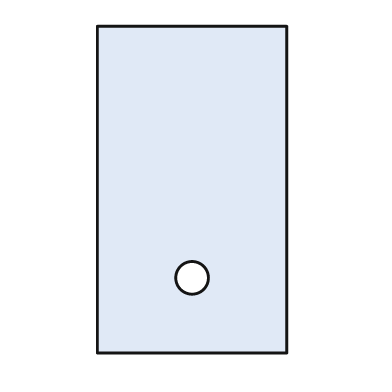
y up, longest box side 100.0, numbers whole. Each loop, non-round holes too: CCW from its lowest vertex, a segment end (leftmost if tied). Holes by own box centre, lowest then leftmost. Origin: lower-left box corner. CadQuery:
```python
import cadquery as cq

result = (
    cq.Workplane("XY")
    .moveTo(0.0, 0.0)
    .lineTo(58.0, 0.0)
    .lineTo(58.0, 100.0)
    .lineTo(0.0, 100.0)
    .close()
    .moveTo(29.0, 23.0)
    .circle(5.0)
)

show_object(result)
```